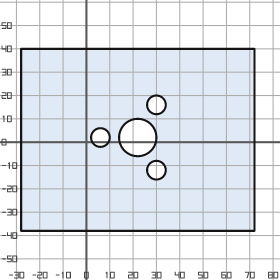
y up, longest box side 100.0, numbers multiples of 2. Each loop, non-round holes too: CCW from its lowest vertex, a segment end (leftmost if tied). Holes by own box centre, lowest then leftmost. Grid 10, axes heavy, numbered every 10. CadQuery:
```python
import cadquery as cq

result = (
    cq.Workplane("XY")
    .moveTo(-28.0, -38.0)
    .lineTo(72.0, -38.0)
    .lineTo(72.0, 40.0)
    .lineTo(-28.0, 40.0)
    .close()
    .moveTo(30.0, -12.0)
    .circle(4.0)
    .moveTo(6.0, 2.0)
    .circle(4.0)
    .moveTo(22.0, 2.0)
    .circle(8.0)
    .moveTo(30.0, 16.0)
    .circle(4.0)
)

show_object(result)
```